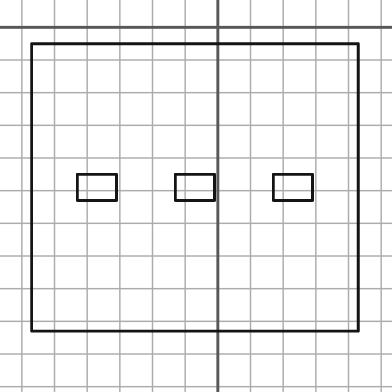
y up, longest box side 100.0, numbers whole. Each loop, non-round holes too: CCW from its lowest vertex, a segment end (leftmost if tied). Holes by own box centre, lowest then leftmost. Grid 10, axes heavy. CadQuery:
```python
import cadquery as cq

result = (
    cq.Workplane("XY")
    .moveTo(-57.0, -93.0)
    .lineTo(43.0, -93.0)
    .lineTo(43.0, -5.0)
    .lineTo(-57.0, -5.0)
    .close()
    .moveTo(-43.0, -53.0)
    .lineTo(-31.0, -53.0)
    .lineTo(-31.0, -45.0)
    .lineTo(-43.0, -45.0)
    .close()
    .moveTo(-13.0, -53.0)
    .lineTo(-1.0, -53.0)
    .lineTo(-1.0, -45.0)
    .lineTo(-13.0, -45.0)
    .close()
    .moveTo(17.0, -53.0)
    .lineTo(29.0, -53.0)
    .lineTo(29.0, -45.0)
    .lineTo(17.0, -45.0)
    .close()
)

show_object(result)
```